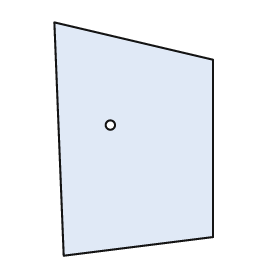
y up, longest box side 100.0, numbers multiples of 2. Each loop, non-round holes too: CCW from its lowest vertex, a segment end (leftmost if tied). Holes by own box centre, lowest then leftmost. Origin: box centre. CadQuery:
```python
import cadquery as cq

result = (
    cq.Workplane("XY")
    .moveTo(-30.0, -50.0)
    .lineTo(34.0, -42.0)
    .lineTo(34.0, 34.0)
    .lineTo(-34.0, 50.0)
    .close()
    .moveTo(-10.0, 6.0)
    .circle(2.0)
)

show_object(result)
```